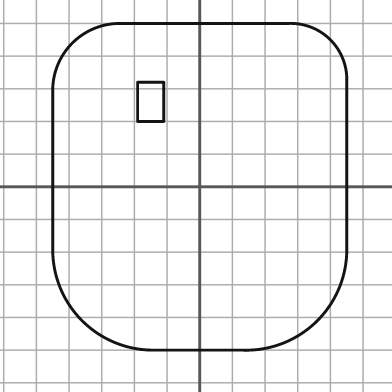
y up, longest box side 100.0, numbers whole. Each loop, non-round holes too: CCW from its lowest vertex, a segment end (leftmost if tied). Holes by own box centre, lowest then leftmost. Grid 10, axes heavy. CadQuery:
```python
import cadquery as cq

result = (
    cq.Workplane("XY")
    .moveTo(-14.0, -50.0)
    .lineTo(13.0, -50.0)
    .threePointArc((36.0, -41.0), (45.0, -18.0))
    .lineTo(45.0, 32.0)
    .threePointArc((40.0, 45.0), (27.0, 50.0))
    .lineTo(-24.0, 50.0)
    .threePointArc((-39.0, 44.0), (-45.0, 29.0))
    .lineTo(-45.0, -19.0)
    .threePointArc((-36.0, -41.0), (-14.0, -50.0))
    .close()
    .moveTo(-19.0, 20.0)
    .lineTo(-11.0, 20.0)
    .lineTo(-11.0, 32.0)
    .lineTo(-19.0, 32.0)
    .close()
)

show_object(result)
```